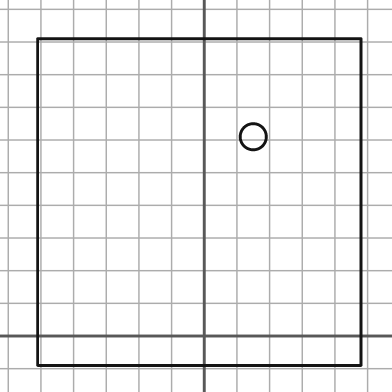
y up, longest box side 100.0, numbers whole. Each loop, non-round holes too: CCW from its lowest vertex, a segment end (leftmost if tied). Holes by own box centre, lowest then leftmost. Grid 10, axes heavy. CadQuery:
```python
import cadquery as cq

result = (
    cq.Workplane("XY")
    .moveTo(-51.0, -9.0)
    .lineTo(48.0, -9.0)
    .lineTo(48.0, 91.0)
    .lineTo(-51.0, 91.0)
    .close()
    .moveTo(15.0, 61.0)
    .circle(4.0)
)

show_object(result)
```